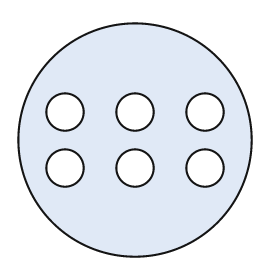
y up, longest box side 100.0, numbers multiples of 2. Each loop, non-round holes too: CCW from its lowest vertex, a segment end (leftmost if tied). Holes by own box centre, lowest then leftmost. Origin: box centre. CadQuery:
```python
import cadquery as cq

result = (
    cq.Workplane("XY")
    .moveTo(0.0, 0.0)
    .circle(50.0)
    .moveTo(-30.0, -12.0)
    .circle(8.0)
    .moveTo(0.0, -12.0)
    .circle(8.0)
    .moveTo(30.0, -12.0)
    .circle(8.0)
    .moveTo(-30.0, 12.0)
    .circle(8.0)
    .moveTo(0.0, 12.0)
    .circle(8.0)
    .moveTo(30.0, 12.0)
    .circle(8.0)
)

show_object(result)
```